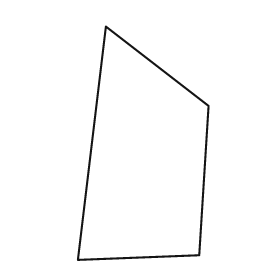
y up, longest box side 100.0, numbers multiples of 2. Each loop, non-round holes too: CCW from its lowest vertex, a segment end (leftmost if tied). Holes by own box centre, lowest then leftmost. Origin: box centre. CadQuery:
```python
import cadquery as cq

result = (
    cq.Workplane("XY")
    .moveTo(-28.0, -50.0)
    .lineTo(24.0, -48.0)
    .lineTo(28.0, 16.0)
    .lineTo(-16.0, 50.0)
    .close()
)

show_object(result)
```